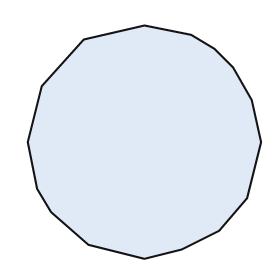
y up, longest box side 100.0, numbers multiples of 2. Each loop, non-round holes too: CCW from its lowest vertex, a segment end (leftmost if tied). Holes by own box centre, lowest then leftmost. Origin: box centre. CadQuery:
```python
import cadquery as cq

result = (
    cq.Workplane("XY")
    .moveTo(0.0, -50.0)
    .lineTo(16.0, -46.0)
    .lineTo(32.0, -38.0)
    .lineTo(44.0, -24.0)
    .lineTo(50.0, 0.0)
    .lineTo(46.0, 18.0)
    .lineTo(38.0, 32.0)
    .lineTo(30.0, 40.0)
    .lineTo(20.0, 46.0)
    .lineTo(0.0, 50.0)
    .lineTo(-26.0, 44.0)
    .lineTo(-44.0, 24.0)
    .lineTo(-50.0, 0.0)
    .lineTo(-46.0, -20.0)
    .lineTo(-40.0, -30.0)
    .lineTo(-24.0, -44.0)
    .close()
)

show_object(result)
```